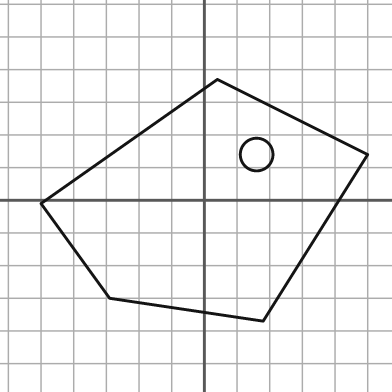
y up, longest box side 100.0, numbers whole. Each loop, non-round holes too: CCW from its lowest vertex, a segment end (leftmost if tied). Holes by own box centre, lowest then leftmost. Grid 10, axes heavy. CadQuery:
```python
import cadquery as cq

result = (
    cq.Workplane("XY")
    .moveTo(18.0, -37.0)
    .lineTo(50.0, 14.0)
    .lineTo(4.0, 37.0)
    .lineTo(-50.0, -1.0)
    .lineTo(-29.0, -30.0)
    .close()
    .moveTo(16.0, 14.0)
    .circle(5.0)
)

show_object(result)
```